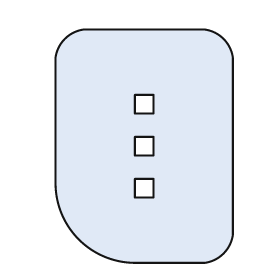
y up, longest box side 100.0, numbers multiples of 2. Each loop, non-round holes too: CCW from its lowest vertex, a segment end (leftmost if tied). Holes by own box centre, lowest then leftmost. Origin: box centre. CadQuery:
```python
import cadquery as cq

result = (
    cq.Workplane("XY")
    .moveTo(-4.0, -50.0)
    .lineTo(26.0, -50.0)
    .threePointArc((34.0, -46.0), (38.0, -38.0))
    .lineTo(38.0, 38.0)
    .threePointArc((34.0, 46.0), (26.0, 50.0))
    .lineTo(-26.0, 50.0)
    .threePointArc((-34.0, 46.0), (-38.0, 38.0))
    .lineTo(-38.0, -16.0)
    .threePointArc((-28.0, -40.0), (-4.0, -50.0))
    .close()
    .moveTo(-4.0, -22.0)
    .lineTo(4.0, -22.0)
    .lineTo(4.0, -14.0)
    .lineTo(-4.0, -14.0)
    .close()
    .moveTo(-4.0, -4.0)
    .lineTo(4.0, -4.0)
    .lineTo(4.0, 4.0)
    .lineTo(-4.0, 4.0)
    .close()
    .moveTo(-4.0, 14.0)
    .lineTo(4.0, 14.0)
    .lineTo(4.0, 22.0)
    .lineTo(-4.0, 22.0)
    .close()
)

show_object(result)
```